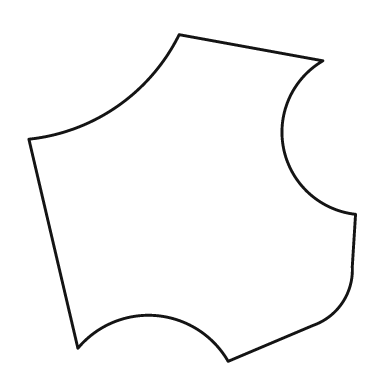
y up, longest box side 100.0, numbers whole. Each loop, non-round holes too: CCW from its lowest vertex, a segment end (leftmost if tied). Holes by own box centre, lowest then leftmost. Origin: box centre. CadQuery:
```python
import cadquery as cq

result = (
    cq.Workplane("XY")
    .moveTo(11.0, -50.0)
    .lineTo(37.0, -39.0)
    .threePointArc((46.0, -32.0), (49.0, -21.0))
    .lineTo(50.0, -5.0)
    .threePointArc((28.0, 15.0), (40.0, 42.0))
    .lineTo(-4.0, 50.0)
    .threePointArc((-23.0, 28.0), (-50.0, 18.0))
    .lineTo(-35.0, -46.0)
    .threePointArc((-11.0, -36.0), (11.0, -50.0))
    .close()
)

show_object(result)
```